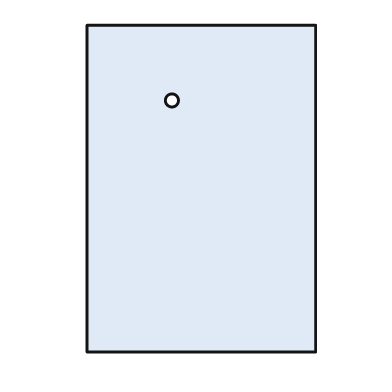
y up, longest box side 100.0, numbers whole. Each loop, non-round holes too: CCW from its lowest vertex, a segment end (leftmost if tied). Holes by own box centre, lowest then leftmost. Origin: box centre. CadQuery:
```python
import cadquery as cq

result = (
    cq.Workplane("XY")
    .moveTo(-35.0, -50.0)
    .lineTo(35.0, -50.0)
    .lineTo(35.0, 50.0)
    .lineTo(-35.0, 50.0)
    .close()
    .moveTo(-9.0, 27.0)
    .circle(2.0)
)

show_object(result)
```